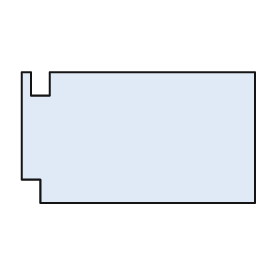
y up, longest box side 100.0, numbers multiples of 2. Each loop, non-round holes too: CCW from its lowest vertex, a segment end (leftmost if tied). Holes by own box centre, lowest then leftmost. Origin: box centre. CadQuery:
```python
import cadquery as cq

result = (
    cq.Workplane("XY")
    .moveTo(-42.0, -28.0)
    .lineTo(50.0, -28.0)
    .lineTo(50.0, 28.0)
    .lineTo(-38.0, 28.0)
    .lineTo(-38.0, 18.0)
    .lineTo(-46.0, 18.0)
    .lineTo(-46.0, 28.0)
    .lineTo(-50.0, 28.0)
    .lineTo(-50.0, -18.0)
    .lineTo(-42.0, -18.0)
    .close()
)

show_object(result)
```